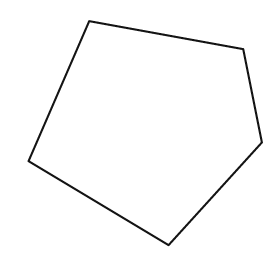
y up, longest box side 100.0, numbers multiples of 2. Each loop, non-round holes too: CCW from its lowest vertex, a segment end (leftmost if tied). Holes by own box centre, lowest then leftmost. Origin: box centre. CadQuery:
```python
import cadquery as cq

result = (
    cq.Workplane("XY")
    .moveTo(10.0, -48.0)
    .lineTo(50.0, -4.0)
    .lineTo(42.0, 36.0)
    .lineTo(-24.0, 48.0)
    .lineTo(-50.0, -12.0)
    .close()
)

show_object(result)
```